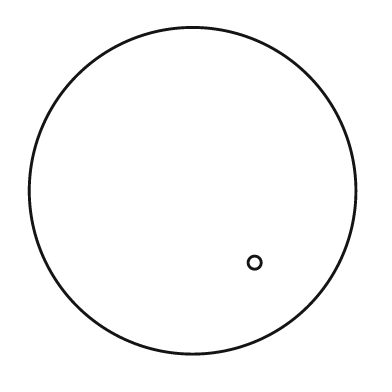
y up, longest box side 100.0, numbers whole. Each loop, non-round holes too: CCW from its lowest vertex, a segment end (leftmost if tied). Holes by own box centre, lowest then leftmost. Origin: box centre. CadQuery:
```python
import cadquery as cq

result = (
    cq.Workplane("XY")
    .moveTo(0.0, 0.0)
    .circle(50.0)
    .moveTo(19.0, -22.0)
    .circle(2.0)
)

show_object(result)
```